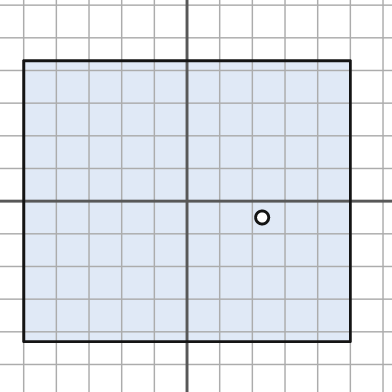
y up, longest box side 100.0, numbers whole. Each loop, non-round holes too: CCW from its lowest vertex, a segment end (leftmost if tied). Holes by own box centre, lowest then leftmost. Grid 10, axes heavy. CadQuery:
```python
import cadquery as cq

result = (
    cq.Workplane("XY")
    .moveTo(-50.0, -43.0)
    .lineTo(50.0, -43.0)
    .lineTo(50.0, 43.0)
    .lineTo(-50.0, 43.0)
    .close()
    .moveTo(23.0, -5.0)
    .circle(2.0)
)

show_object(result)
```